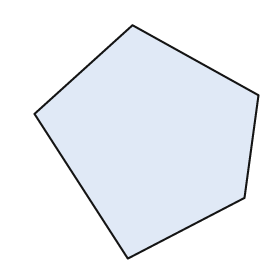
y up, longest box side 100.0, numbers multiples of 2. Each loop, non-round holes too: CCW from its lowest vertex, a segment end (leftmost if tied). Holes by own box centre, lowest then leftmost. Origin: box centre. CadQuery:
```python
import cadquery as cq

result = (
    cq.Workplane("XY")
    .moveTo(-8.0, -50.0)
    .lineTo(42.0, -24.0)
    .lineTo(48.0, 20.0)
    .lineTo(-6.0, 50.0)
    .lineTo(-48.0, 12.0)
    .close()
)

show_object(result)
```